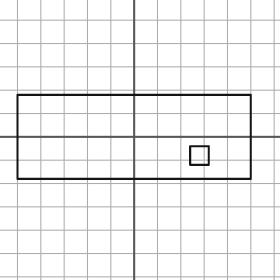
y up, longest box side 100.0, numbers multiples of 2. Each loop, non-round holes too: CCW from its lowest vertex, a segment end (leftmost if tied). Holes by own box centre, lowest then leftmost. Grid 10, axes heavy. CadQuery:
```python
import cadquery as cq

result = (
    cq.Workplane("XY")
    .moveTo(-50.0, -18.0)
    .lineTo(50.0, -18.0)
    .lineTo(50.0, 18.0)
    .lineTo(-50.0, 18.0)
    .close()
    .moveTo(24.0, -12.0)
    .lineTo(32.0, -12.0)
    .lineTo(32.0, -4.0)
    .lineTo(24.0, -4.0)
    .close()
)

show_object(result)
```